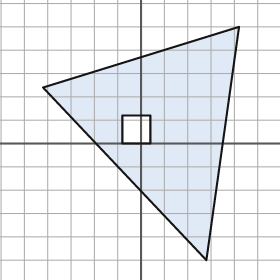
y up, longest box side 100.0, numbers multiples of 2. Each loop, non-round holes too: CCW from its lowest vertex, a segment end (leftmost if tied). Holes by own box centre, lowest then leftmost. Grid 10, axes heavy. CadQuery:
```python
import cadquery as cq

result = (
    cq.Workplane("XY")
    .moveTo(28.0, -50.0)
    .lineTo(42.0, 50.0)
    .lineTo(-42.0, 24.0)
    .close()
    .moveTo(-8.0, 0.0)
    .lineTo(4.0, 0.0)
    .lineTo(4.0, 12.0)
    .lineTo(-8.0, 12.0)
    .close()
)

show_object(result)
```